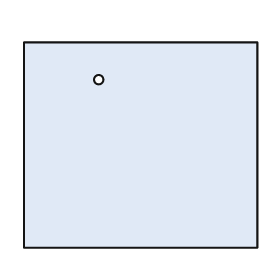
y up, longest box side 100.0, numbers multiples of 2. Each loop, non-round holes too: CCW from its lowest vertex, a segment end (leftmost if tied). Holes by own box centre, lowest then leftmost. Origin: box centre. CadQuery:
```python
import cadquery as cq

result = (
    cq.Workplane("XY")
    .moveTo(-50.0, -44.0)
    .lineTo(50.0, -44.0)
    .lineTo(50.0, 44.0)
    .lineTo(-50.0, 44.0)
    .close()
    .moveTo(-18.0, 28.0)
    .circle(2.0)
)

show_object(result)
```